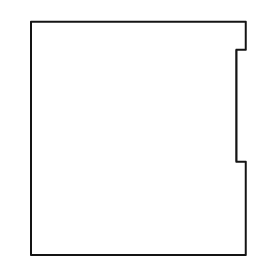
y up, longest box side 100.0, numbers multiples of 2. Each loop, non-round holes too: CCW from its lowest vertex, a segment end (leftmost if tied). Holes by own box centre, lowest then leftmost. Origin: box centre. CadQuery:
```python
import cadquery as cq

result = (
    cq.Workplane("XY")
    .moveTo(-46.0, -50.0)
    .lineTo(46.0, -50.0)
    .lineTo(46.0, -10.0)
    .lineTo(42.0, -10.0)
    .lineTo(42.0, 38.0)
    .lineTo(46.0, 38.0)
    .lineTo(46.0, 50.0)
    .lineTo(-46.0, 50.0)
    .close()
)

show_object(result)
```